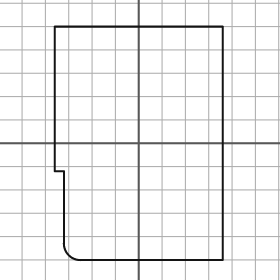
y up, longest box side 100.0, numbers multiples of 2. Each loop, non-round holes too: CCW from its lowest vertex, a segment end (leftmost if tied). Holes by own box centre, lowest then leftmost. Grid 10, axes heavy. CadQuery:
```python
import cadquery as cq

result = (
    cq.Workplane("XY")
    .moveTo(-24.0, -50.0)
    .lineTo(36.0, -50.0)
    .lineTo(36.0, 50.0)
    .lineTo(-36.0, 50.0)
    .lineTo(-36.0, -12.0)
    .lineTo(-32.0, -12.0)
    .lineTo(-32.0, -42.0)
    .threePointArc((-30.0, -48.0), (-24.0, -50.0))
    .close()
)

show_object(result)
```